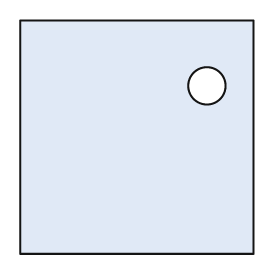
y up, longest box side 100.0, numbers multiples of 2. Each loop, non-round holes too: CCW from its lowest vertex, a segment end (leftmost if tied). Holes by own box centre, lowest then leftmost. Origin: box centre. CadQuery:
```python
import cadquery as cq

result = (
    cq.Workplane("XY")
    .moveTo(-50.0, -50.0)
    .lineTo(50.0, -50.0)
    .lineTo(50.0, 50.0)
    .lineTo(-50.0, 50.0)
    .close()
    .moveTo(30.0, 22.0)
    .circle(8.0)
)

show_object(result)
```